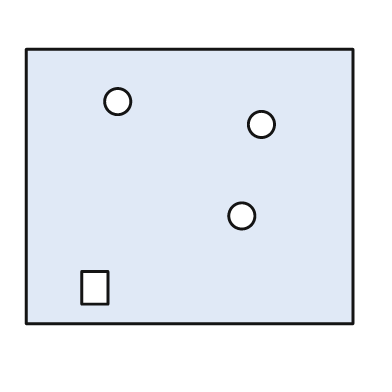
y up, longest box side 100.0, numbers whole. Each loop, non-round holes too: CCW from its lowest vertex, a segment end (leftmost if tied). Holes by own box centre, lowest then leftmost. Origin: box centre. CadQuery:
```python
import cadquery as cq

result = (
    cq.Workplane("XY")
    .moveTo(-50.0, -42.0)
    .lineTo(50.0, -42.0)
    .lineTo(50.0, 42.0)
    .lineTo(-50.0, 42.0)
    .close()
    .moveTo(-33.0, -36.0)
    .lineTo(-25.0, -36.0)
    .lineTo(-25.0, -26.0)
    .lineTo(-33.0, -26.0)
    .close()
    .moveTo(16.0, -9.0)
    .circle(4.0)
    .moveTo(22.0, 19.0)
    .circle(4.0)
    .moveTo(-22.0, 26.0)
    .circle(4.0)
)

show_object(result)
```